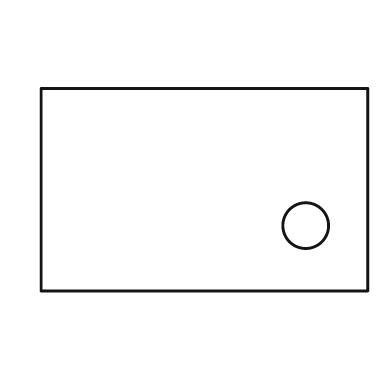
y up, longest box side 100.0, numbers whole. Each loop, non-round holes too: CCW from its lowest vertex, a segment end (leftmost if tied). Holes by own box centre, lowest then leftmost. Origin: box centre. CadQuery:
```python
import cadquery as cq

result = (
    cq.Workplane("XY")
    .moveTo(-50.0, -31.0)
    .lineTo(50.0, -31.0)
    .lineTo(50.0, 31.0)
    .lineTo(-50.0, 31.0)
    .close()
    .moveTo(31.0, -11.0)
    .circle(7.0)
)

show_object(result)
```